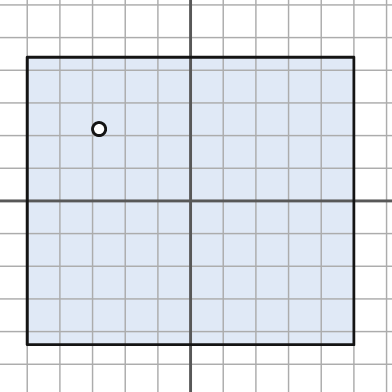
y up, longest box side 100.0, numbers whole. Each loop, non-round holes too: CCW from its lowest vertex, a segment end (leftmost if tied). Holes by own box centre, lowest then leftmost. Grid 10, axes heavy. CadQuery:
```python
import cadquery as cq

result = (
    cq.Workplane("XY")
    .moveTo(-50.0, -44.0)
    .lineTo(50.0, -44.0)
    .lineTo(50.0, 44.0)
    .lineTo(-50.0, 44.0)
    .close()
    .moveTo(-28.0, 22.0)
    .circle(2.0)
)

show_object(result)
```